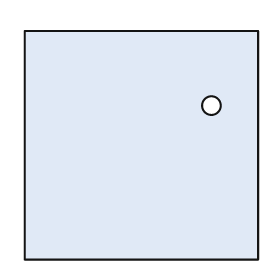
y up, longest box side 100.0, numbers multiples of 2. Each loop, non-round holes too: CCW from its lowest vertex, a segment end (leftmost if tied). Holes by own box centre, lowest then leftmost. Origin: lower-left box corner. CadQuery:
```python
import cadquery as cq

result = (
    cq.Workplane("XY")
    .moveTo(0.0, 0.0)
    .lineTo(100.0, 0.0)
    .lineTo(100.0, 98.0)
    .lineTo(0.0, 98.0)
    .close()
    .moveTo(80.0, 66.0)
    .circle(4.0)
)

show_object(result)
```